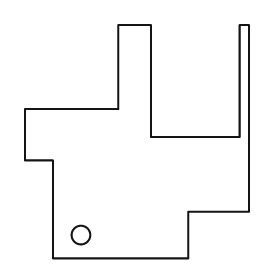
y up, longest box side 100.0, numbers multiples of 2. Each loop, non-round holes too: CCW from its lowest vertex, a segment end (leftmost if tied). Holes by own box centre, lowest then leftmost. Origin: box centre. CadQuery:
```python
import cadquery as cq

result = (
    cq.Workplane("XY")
    .moveTo(-36.0, -50.0)
    .lineTo(22.0, -50.0)
    .lineTo(22.0, -30.0)
    .lineTo(48.0, -30.0)
    .lineTo(48.0, 50.0)
    .lineTo(44.0, 50.0)
    .lineTo(44.0, 2.0)
    .lineTo(6.0, 2.0)
    .lineTo(6.0, 50.0)
    .lineTo(-8.0, 50.0)
    .lineTo(-8.0, 14.0)
    .lineTo(-48.0, 14.0)
    .lineTo(-48.0, -8.0)
    .lineTo(-36.0, -8.0)
    .close()
    .moveTo(-24.0, -40.0)
    .circle(4.0)
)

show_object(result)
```